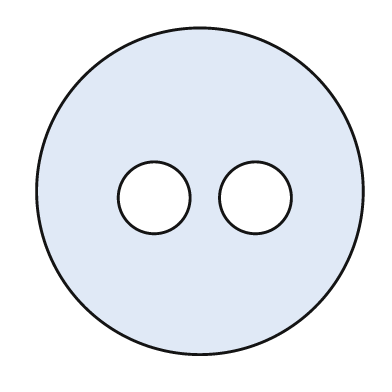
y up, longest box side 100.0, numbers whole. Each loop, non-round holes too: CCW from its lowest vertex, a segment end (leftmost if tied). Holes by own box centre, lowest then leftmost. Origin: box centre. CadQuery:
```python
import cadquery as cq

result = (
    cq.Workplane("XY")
    .moveTo(0.0, 0.0)
    .circle(50.0)
    .moveTo(-14.0, -2.0)
    .circle(11.0)
    .moveTo(17.0, -2.0)
    .circle(11.0)
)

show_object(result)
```